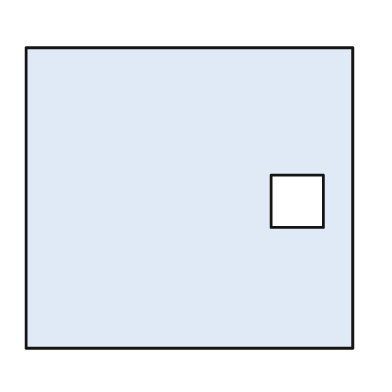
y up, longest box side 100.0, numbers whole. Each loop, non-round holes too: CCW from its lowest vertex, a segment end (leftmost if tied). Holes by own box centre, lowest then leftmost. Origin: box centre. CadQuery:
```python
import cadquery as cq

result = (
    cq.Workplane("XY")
    .moveTo(-50.0, -46.0)
    .lineTo(50.0, -46.0)
    .lineTo(50.0, 46.0)
    .lineTo(-50.0, 46.0)
    .close()
    .moveTo(25.0, -9.0)
    .lineTo(41.0, -9.0)
    .lineTo(41.0, 7.0)
    .lineTo(25.0, 7.0)
    .close()
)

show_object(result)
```